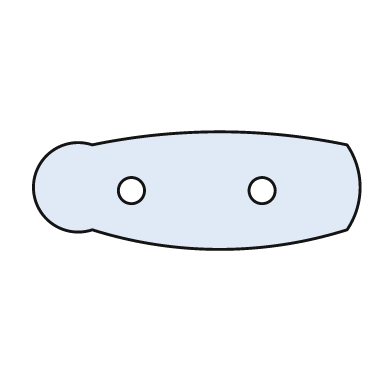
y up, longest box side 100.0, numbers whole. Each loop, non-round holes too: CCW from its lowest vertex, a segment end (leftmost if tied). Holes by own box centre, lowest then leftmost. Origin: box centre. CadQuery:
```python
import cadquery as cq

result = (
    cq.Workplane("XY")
    .moveTo(-32.0, -12.0)
    .threePointArc((7.0, -18.0), (46.0, -12.0))
    .threePointArc((50.0, 1.0), (46.0, 14.0))
    .threePointArc((7.0, 18.0), (-32.0, 14.0))
    .threePointArc((-50.0, 1.0), (-32.0, -12.0))
    .close()
    .moveTo(-20.0, 0.0)
    .circle(4.0)
    .moveTo(20.0, 0.0)
    .circle(4.0)
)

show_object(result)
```